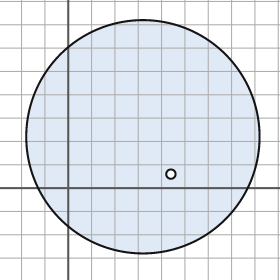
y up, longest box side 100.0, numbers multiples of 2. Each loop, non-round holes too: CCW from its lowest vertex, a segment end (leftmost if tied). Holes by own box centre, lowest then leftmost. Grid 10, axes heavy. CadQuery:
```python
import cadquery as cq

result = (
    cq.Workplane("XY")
    .moveTo(32.0, 22.0)
    .circle(50.0)
    .moveTo(44.0, 6.0)
    .circle(2.0)
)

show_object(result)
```